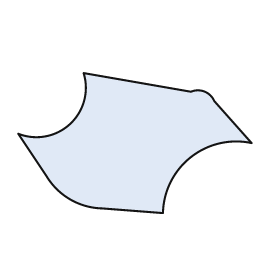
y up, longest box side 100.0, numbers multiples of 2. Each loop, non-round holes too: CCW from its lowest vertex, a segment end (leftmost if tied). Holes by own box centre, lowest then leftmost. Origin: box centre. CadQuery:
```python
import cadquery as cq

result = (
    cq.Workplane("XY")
    .moveTo(12.0, -30.0)
    .threePointArc((24.0, -6.0), (50.0, 0.0))
    .lineTo(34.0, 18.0)
    .threePointArc((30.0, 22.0), (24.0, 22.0))
    .lineTo(-22.0, 30.0)
    .threePointArc((-28.0, 8.0), (-50.0, 4.0))
    .lineTo(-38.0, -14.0)
    .threePointArc((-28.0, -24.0), (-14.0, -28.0))
    .close()
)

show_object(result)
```